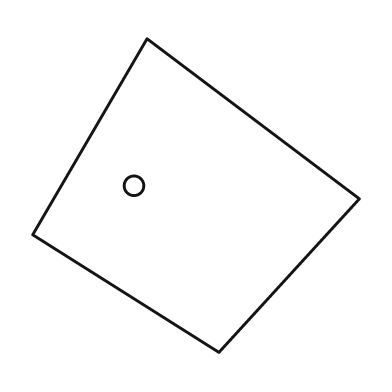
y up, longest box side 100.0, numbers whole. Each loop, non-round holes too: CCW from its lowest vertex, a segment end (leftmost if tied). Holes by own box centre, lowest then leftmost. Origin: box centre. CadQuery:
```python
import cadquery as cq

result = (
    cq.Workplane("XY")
    .moveTo(7.0, -48.0)
    .lineTo(50.0, -1.0)
    .lineTo(-15.0, 48.0)
    .lineTo(-50.0, -12.0)
    .close()
    .moveTo(-19.0, 3.0)
    .circle(3.0)
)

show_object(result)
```